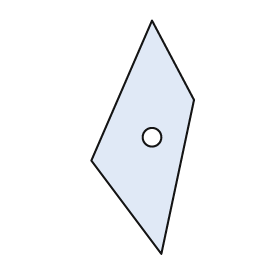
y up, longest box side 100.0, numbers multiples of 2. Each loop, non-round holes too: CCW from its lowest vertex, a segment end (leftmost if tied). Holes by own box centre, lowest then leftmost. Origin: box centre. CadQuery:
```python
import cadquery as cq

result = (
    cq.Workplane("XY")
    .moveTo(8.0, -50.0)
    .lineTo(22.0, 16.0)
    .lineTo(4.0, 50.0)
    .lineTo(-22.0, -10.0)
    .close()
    .moveTo(4.0, 0.0)
    .circle(4.0)
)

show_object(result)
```